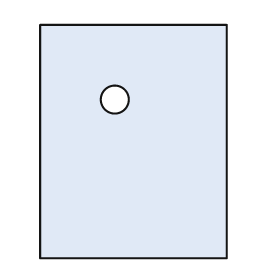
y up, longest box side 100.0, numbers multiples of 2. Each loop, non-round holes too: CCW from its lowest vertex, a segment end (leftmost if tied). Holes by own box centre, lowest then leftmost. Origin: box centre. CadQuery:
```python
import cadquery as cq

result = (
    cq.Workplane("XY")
    .moveTo(-40.0, -50.0)
    .lineTo(40.0, -50.0)
    .lineTo(40.0, 50.0)
    .lineTo(-40.0, 50.0)
    .close()
    .moveTo(-8.0, 18.0)
    .circle(6.0)
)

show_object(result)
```